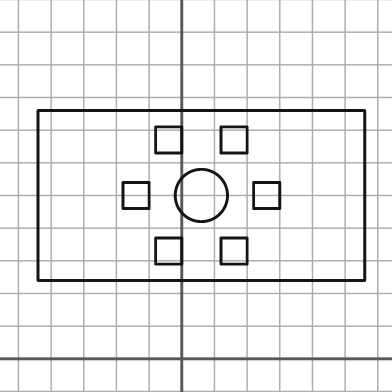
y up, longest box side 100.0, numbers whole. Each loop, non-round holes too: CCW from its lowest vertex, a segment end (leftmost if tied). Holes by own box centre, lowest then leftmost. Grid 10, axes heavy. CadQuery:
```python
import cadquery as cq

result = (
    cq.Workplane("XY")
    .moveTo(-44.0, 24.0)
    .lineTo(56.0, 24.0)
    .lineTo(56.0, 76.0)
    .lineTo(-44.0, 76.0)
    .close()
    .moveTo(-8.0, 29.0)
    .lineTo(0.0, 29.0)
    .lineTo(0.0, 37.0)
    .lineTo(-8.0, 37.0)
    .close()
    .moveTo(12.0, 29.0)
    .lineTo(20.0, 29.0)
    .lineTo(20.0, 37.0)
    .lineTo(12.0, 37.0)
    .close()
    .moveTo(-18.0, 46.0)
    .lineTo(-10.0, 46.0)
    .lineTo(-10.0, 54.0)
    .lineTo(-18.0, 54.0)
    .close()
    .moveTo(6.0, 50.0)
    .circle(8.0)
    .moveTo(22.0, 46.0)
    .lineTo(30.0, 46.0)
    .lineTo(30.0, 54.0)
    .lineTo(22.0, 54.0)
    .close()
    .moveTo(-8.0, 63.0)
    .lineTo(0.0, 63.0)
    .lineTo(0.0, 71.0)
    .lineTo(-8.0, 71.0)
    .close()
    .moveTo(12.0, 63.0)
    .lineTo(20.0, 63.0)
    .lineTo(20.0, 71.0)
    .lineTo(12.0, 71.0)
    .close()
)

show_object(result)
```